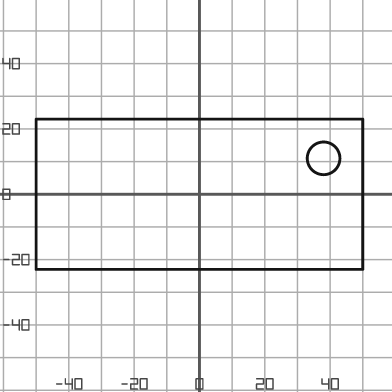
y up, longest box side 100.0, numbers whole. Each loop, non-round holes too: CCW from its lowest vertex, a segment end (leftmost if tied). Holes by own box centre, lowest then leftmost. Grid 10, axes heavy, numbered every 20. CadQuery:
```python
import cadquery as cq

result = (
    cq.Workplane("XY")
    .moveTo(-50.0, -23.0)
    .lineTo(50.0, -23.0)
    .lineTo(50.0, 23.0)
    .lineTo(-50.0, 23.0)
    .close()
    .moveTo(38.0, 11.0)
    .circle(5.0)
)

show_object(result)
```